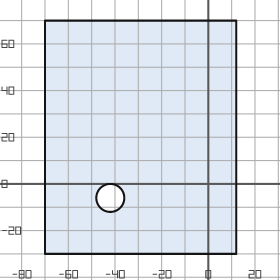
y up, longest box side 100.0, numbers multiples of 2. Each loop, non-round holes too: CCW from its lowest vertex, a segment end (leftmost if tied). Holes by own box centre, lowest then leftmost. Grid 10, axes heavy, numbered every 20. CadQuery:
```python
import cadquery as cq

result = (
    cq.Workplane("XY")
    .moveTo(-70.0, -30.0)
    .lineTo(12.0, -30.0)
    .lineTo(12.0, 70.0)
    .lineTo(-70.0, 70.0)
    .close()
    .moveTo(-42.0, -6.0)
    .circle(6.0)
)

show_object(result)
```